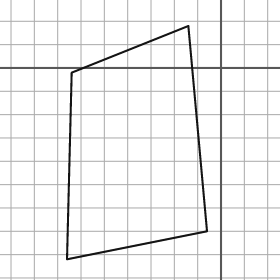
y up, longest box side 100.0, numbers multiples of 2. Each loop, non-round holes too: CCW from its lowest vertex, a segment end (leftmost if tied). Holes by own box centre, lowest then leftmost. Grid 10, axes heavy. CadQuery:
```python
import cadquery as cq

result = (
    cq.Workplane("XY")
    .moveTo(-66.0, -82.0)
    .lineTo(-6.0, -70.0)
    .lineTo(-14.0, 18.0)
    .lineTo(-64.0, -2.0)
    .close()
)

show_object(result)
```